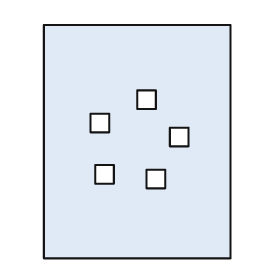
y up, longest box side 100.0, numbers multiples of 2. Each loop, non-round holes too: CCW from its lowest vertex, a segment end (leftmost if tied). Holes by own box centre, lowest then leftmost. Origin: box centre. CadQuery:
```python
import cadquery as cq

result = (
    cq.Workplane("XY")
    .moveTo(-40.0, -50.0)
    .lineTo(40.0, -50.0)
    .lineTo(40.0, 50.0)
    .lineTo(-40.0, 50.0)
    .close()
    .moveTo(4.0, -20.0)
    .lineTo(12.0, -20.0)
    .lineTo(12.0, -12.0)
    .lineTo(4.0, -12.0)
    .close()
    .moveTo(-18.0, -18.0)
    .lineTo(-10.0, -18.0)
    .lineTo(-10.0, -10.0)
    .lineTo(-18.0, -10.0)
    .close()
    .moveTo(14.0, -2.0)
    .lineTo(22.0, -2.0)
    .lineTo(22.0, 6.0)
    .lineTo(14.0, 6.0)
    .close()
    .moveTo(-20.0, 4.0)
    .lineTo(-12.0, 4.0)
    .lineTo(-12.0, 12.0)
    .lineTo(-20.0, 12.0)
    .close()
    .moveTo(0.0, 14.0)
    .lineTo(8.0, 14.0)
    .lineTo(8.0, 22.0)
    .lineTo(0.0, 22.0)
    .close()
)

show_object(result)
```